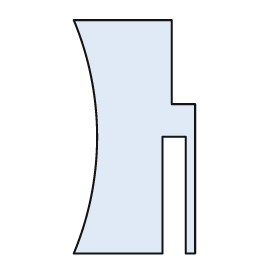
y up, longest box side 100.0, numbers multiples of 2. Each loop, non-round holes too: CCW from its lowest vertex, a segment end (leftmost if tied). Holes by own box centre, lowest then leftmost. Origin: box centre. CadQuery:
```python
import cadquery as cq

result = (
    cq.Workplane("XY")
    .moveTo(-26.0, -50.0)
    .lineTo(12.0, -50.0)
    .lineTo(12.0, 0.0)
    .lineTo(22.0, 0.0)
    .lineTo(22.0, -50.0)
    .lineTo(26.0, -50.0)
    .lineTo(26.0, 14.0)
    .lineTo(16.0, 14.0)
    .lineTo(16.0, 50.0)
    .lineTo(-26.0, 50.0)
    .threePointArc((-16.0, 0.0), (-26.0, -50.0))
    .close()
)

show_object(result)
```